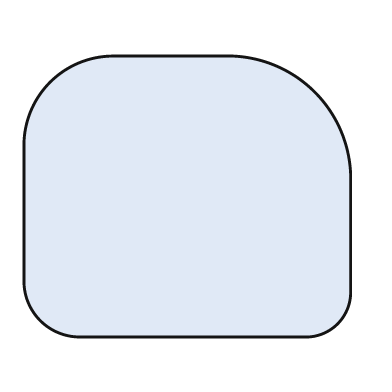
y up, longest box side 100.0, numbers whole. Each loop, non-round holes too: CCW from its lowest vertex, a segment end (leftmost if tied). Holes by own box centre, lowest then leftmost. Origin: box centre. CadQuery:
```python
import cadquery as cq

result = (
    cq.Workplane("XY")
    .moveTo(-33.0, -43.0)
    .lineTo(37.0, -43.0)
    .threePointArc((46.0, -39.0), (50.0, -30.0))
    .lineTo(50.0, 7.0)
    .threePointArc((39.0, 32.0), (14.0, 43.0))
    .lineTo(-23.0, 43.0)
    .threePointArc((-42.0, 35.0), (-50.0, 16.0))
    .lineTo(-50.0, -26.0)
    .threePointArc((-45.0, -38.0), (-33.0, -43.0))
    .close()
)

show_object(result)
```